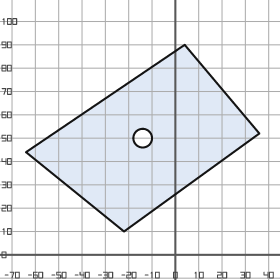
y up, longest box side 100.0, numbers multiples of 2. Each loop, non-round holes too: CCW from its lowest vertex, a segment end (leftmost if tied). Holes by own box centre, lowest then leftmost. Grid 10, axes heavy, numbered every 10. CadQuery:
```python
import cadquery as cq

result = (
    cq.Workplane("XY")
    .moveTo(-22.0, 10.0)
    .lineTo(36.0, 52.0)
    .lineTo(4.0, 90.0)
    .lineTo(-64.0, 44.0)
    .close()
    .moveTo(-14.0, 50.0)
    .circle(4.0)
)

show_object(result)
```